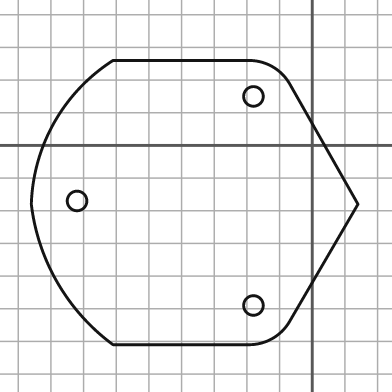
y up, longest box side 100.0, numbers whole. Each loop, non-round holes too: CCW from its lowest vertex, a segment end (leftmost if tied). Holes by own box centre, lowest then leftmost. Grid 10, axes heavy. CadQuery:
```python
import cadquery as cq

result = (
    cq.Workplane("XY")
    .moveTo(-61.0, -61.0)
    .lineTo(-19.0, -61.0)
    .threePointArc((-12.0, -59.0), (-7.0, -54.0))
    .lineTo(14.0, -18.0)
    .lineTo(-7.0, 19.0)
    .threePointArc((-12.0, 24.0), (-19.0, 26.0))
    .lineTo(-61.0, 26.0)
    .threePointArc((-79.0, 7.0), (-86.0, -18.0))
    .threePointArc((-78.0, -42.0), (-61.0, -61.0))
    .close()
    .moveTo(-18.0, -49.0)
    .circle(3.0)
    .moveTo(-72.0, -17.0)
    .circle(3.0)
    .moveTo(-18.0, 15.0)
    .circle(3.0)
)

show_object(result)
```